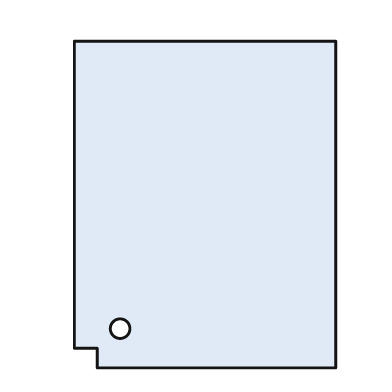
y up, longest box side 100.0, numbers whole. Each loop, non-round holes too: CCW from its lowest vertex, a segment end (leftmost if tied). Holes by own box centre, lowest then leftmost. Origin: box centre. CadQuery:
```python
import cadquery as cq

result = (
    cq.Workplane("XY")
    .moveTo(-33.0, -50.0)
    .lineTo(40.0, -50.0)
    .lineTo(40.0, 50.0)
    .lineTo(-40.0, 50.0)
    .lineTo(-40.0, -44.0)
    .lineTo(-33.0, -44.0)
    .close()
    .moveTo(-26.0, -38.0)
    .circle(3.0)
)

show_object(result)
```